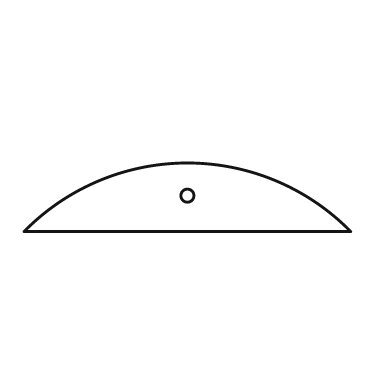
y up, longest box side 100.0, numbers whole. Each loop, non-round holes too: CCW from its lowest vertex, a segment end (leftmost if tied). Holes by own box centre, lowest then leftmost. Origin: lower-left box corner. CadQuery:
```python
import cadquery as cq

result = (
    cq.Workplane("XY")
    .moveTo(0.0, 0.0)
    .lineTo(100.0, 0.0)
    .threePointArc((50.0, 21.0), (0.0, 0.0))
    .close()
    .moveTo(50.0, 11.0)
    .circle(2.0)
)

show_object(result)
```